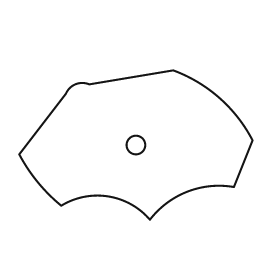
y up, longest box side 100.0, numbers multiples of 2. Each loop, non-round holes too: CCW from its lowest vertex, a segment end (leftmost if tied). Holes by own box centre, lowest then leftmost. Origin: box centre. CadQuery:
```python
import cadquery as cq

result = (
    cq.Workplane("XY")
    .moveTo(6.0, -32.0)
    .threePointArc((22.0, -20.0), (42.0, -18.0))
    .lineTo(50.0, 2.0)
    .threePointArc((36.0, 20.0), (16.0, 32.0))
    .lineTo(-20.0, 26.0)
    .threePointArc((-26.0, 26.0), (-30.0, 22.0))
    .lineTo(-50.0, -4.0)
    .threePointArc((-42.0, -16.0), (-32.0, -26.0))
    .threePointArc((-12.0, -22.0), (6.0, -32.0))
    .close()
    .moveTo(0.0, 0.0)
    .circle(4.0)
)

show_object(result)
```